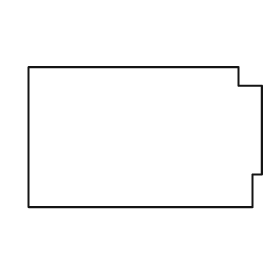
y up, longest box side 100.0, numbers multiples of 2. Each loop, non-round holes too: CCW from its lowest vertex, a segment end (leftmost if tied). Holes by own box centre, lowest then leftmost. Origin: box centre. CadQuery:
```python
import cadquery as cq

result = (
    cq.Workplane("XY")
    .moveTo(-50.0, -30.0)
    .lineTo(46.0, -30.0)
    .lineTo(46.0, -16.0)
    .lineTo(50.0, -16.0)
    .lineTo(50.0, 22.0)
    .lineTo(40.0, 22.0)
    .lineTo(40.0, 30.0)
    .lineTo(-50.0, 30.0)
    .close()
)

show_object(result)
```